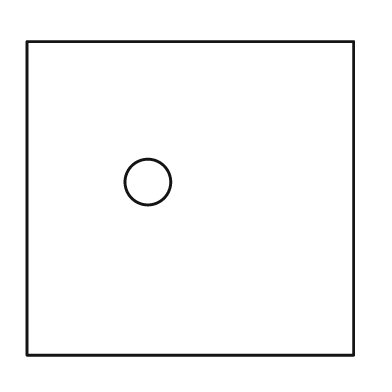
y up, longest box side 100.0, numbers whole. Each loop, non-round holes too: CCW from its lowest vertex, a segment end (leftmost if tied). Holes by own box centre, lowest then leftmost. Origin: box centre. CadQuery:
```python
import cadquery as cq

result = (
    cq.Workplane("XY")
    .moveTo(-50.0, -48.0)
    .lineTo(50.0, -48.0)
    .lineTo(50.0, 48.0)
    .lineTo(-50.0, 48.0)
    .close()
    .moveTo(-13.0, 5.0)
    .circle(7.0)
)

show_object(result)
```